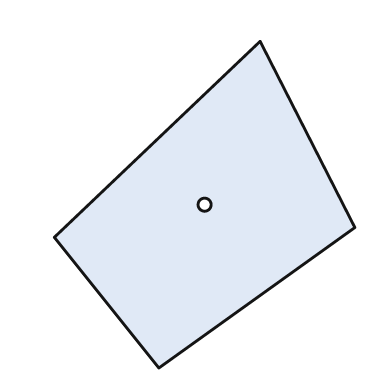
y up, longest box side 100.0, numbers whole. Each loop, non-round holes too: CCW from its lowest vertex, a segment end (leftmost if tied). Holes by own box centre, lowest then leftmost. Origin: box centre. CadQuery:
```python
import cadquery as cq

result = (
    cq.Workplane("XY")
    .moveTo(-14.0, -50.0)
    .lineTo(46.0, -7.0)
    .lineTo(17.0, 50.0)
    .lineTo(-46.0, -10.0)
    .close()
    .moveTo(0.0, 0.0)
    .circle(2.0)
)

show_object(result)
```